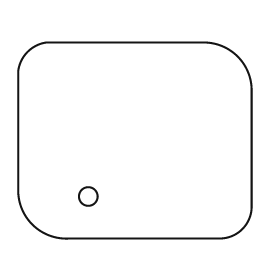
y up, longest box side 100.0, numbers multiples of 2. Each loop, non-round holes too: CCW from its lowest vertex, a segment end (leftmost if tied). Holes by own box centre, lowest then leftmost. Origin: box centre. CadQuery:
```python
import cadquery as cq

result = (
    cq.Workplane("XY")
    .moveTo(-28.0, -42.0)
    .lineTo(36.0, -42.0)
    .threePointArc((46.0, -38.0), (50.0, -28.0))
    .lineTo(50.0, 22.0)
    .threePointArc((44.0, 36.0), (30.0, 42.0))
    .lineTo(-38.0, 42.0)
    .threePointArc((-46.0, 38.0), (-50.0, 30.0))
    .lineTo(-50.0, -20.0)
    .threePointArc((-44.0, -36.0), (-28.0, -42.0))
    .close()
    .moveTo(-20.0, -24.0)
    .circle(4.0)
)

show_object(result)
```